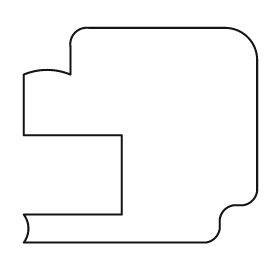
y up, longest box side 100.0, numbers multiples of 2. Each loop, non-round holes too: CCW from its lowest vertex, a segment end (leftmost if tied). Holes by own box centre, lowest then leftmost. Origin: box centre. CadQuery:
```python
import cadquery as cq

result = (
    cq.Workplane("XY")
    .moveTo(-50.0, -46.0)
    .lineTo(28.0, -46.0)
    .threePointArc((32.0, -44.0), (34.0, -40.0))
    .lineTo(34.0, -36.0)
    .threePointArc((36.0, -32.0), (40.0, -30.0))
    .lineTo(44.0, -30.0)
    .threePointArc((48.0, -28.0), (50.0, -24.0))
    .lineTo(50.0, 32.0)
    .threePointArc((46.0, 42.0), (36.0, 46.0))
    .lineTo(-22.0, 46.0)
    .threePointArc((-28.0, 44.0), (-30.0, 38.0))
    .lineTo(-30.0, 26.0)
    .threePointArc((-40.0, 28.0), (-50.0, 26.0))
    .lineTo(-50.0, 0.0)
    .lineTo(-8.0, 0.0)
    .lineTo(-8.0, -34.0)
    .lineTo(-50.0, -34.0)
    .threePointArc((-48.0, -40.0), (-50.0, -46.0))
    .close()
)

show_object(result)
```